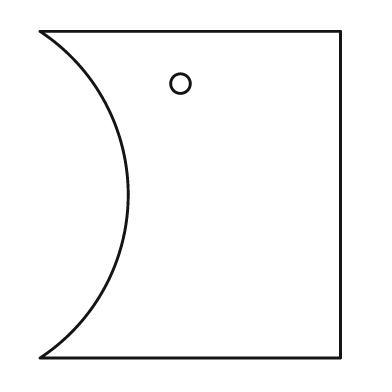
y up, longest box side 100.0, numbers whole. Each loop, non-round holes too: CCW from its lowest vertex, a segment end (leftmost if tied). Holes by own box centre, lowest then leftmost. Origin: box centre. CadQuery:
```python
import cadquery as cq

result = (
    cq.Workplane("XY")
    .moveTo(-46.0, -50.0)
    .lineTo(46.0, -50.0)
    .lineTo(46.0, 50.0)
    .lineTo(-46.0, 50.0)
    .threePointArc((-19.0, 0.0), (-46.0, -50.0))
    .close()
    .moveTo(-3.0, 34.0)
    .circle(3.0)
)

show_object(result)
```